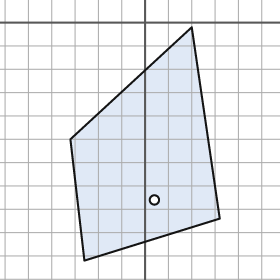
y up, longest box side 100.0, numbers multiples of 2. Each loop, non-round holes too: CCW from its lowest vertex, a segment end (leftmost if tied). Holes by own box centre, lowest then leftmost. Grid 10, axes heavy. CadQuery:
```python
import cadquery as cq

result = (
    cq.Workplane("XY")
    .moveTo(-26.0, -102.0)
    .lineTo(32.0, -84.0)
    .lineTo(20.0, -2.0)
    .lineTo(-32.0, -50.0)
    .close()
    .moveTo(4.0, -76.0)
    .circle(2.0)
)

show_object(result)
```